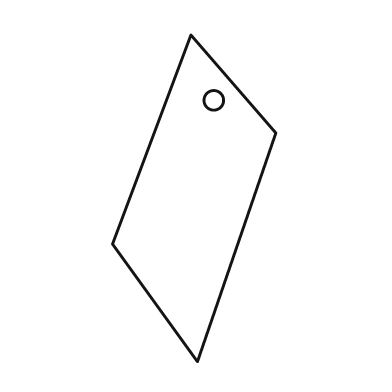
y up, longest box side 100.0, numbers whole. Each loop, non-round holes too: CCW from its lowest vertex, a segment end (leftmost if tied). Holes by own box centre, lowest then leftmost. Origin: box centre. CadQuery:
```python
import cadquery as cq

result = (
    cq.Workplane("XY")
    .moveTo(1.0, -50.0)
    .lineTo(25.0, 20.0)
    .lineTo(-1.0, 50.0)
    .lineTo(-25.0, -14.0)
    .close()
    .moveTo(6.0, 30.0)
    .circle(3.0)
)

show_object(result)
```